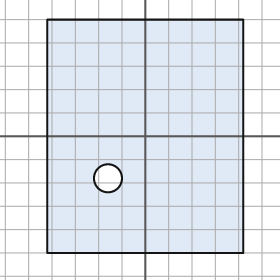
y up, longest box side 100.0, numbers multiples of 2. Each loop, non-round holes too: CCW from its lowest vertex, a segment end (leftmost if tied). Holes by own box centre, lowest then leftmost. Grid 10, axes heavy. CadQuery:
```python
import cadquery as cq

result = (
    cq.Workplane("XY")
    .moveTo(-42.0, -50.0)
    .lineTo(42.0, -50.0)
    .lineTo(42.0, 50.0)
    .lineTo(-42.0, 50.0)
    .close()
    .moveTo(-16.0, -18.0)
    .circle(6.0)
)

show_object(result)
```